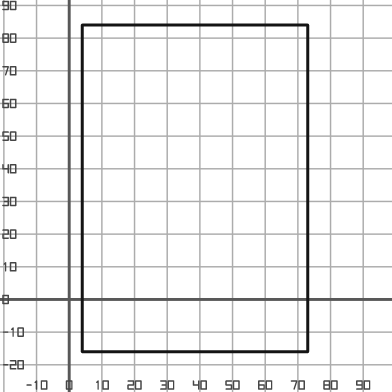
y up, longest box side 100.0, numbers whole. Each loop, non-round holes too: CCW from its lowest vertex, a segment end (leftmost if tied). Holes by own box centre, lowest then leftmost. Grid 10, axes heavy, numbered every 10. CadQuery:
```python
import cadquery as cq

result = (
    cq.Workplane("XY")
    .moveTo(4.0, -16.0)
    .lineTo(73.0, -16.0)
    .lineTo(73.0, 84.0)
    .lineTo(4.0, 84.0)
    .close()
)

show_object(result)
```